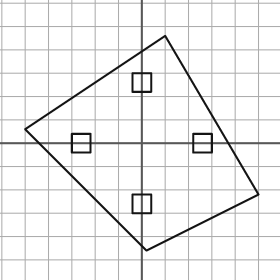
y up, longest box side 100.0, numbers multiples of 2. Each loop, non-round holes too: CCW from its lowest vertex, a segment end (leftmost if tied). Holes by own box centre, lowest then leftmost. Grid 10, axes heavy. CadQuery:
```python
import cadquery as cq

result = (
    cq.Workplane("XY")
    .moveTo(2.0, -46.0)
    .lineTo(50.0, -22.0)
    .lineTo(10.0, 46.0)
    .lineTo(-50.0, 6.0)
    .close()
    .moveTo(-4.0, -30.0)
    .lineTo(4.0, -30.0)
    .lineTo(4.0, -22.0)
    .lineTo(-4.0, -22.0)
    .close()
    .moveTo(-30.0, -4.0)
    .lineTo(-22.0, -4.0)
    .lineTo(-22.0, 4.0)
    .lineTo(-30.0, 4.0)
    .close()
    .moveTo(22.0, -4.0)
    .lineTo(30.0, -4.0)
    .lineTo(30.0, 4.0)
    .lineTo(22.0, 4.0)
    .close()
    .moveTo(-4.0, 22.0)
    .lineTo(4.0, 22.0)
    .lineTo(4.0, 30.0)
    .lineTo(-4.0, 30.0)
    .close()
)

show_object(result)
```